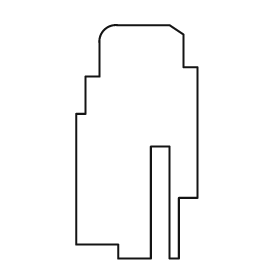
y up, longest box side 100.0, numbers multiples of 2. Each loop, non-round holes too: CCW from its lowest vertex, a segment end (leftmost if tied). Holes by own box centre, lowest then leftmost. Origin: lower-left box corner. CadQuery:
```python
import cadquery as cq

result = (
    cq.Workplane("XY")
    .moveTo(18.0, 0.0)
    .lineTo(32.0, 0.0)
    .lineTo(32.0, 48.0)
    .lineTo(40.0, 48.0)
    .lineTo(40.0, 0.0)
    .lineTo(44.0, 0.0)
    .lineTo(44.0, 26.0)
    .lineTo(52.0, 26.0)
    .lineTo(52.0, 82.0)
    .lineTo(46.0, 82.0)
    .lineTo(46.0, 96.0)
    .lineTo(40.0, 100.0)
    .lineTo(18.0, 100.0)
    .threePointArc((12.0, 98.0), (10.0, 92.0))
    .lineTo(10.0, 78.0)
    .lineTo(4.0, 78.0)
    .lineTo(4.0, 62.0)
    .lineTo(0.0, 62.0)
    .lineTo(0.0, 6.0)
    .lineTo(18.0, 6.0)
    .close()
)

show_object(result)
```